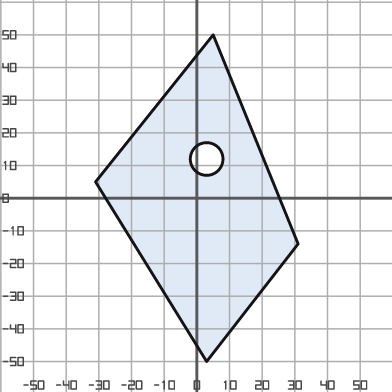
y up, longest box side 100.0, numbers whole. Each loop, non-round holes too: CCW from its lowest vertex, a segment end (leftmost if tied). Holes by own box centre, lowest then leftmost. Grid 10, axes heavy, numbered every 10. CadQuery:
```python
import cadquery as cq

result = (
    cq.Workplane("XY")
    .moveTo(3.0, -50.0)
    .lineTo(31.0, -14.0)
    .lineTo(5.0, 50.0)
    .lineTo(-31.0, 5.0)
    .close()
    .moveTo(3.0, 12.0)
    .circle(5.0)
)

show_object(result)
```